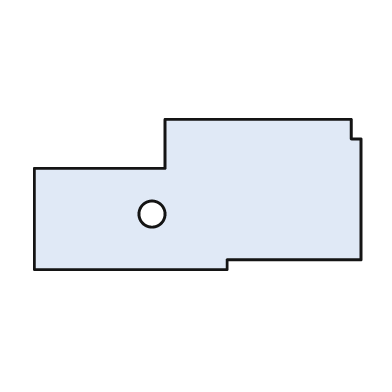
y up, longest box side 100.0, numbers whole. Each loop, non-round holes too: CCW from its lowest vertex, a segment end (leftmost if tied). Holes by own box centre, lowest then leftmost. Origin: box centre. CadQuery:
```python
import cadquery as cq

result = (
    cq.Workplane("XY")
    .moveTo(-50.0, -23.0)
    .lineTo(9.0, -23.0)
    .lineTo(9.0, -20.0)
    .lineTo(50.0, -20.0)
    .lineTo(50.0, 17.0)
    .lineTo(47.0, 17.0)
    .lineTo(47.0, 23.0)
    .lineTo(-10.0, 23.0)
    .lineTo(-10.0, 8.0)
    .lineTo(-50.0, 8.0)
    .close()
    .moveTo(-14.0, -6.0)
    .circle(4.0)
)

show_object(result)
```